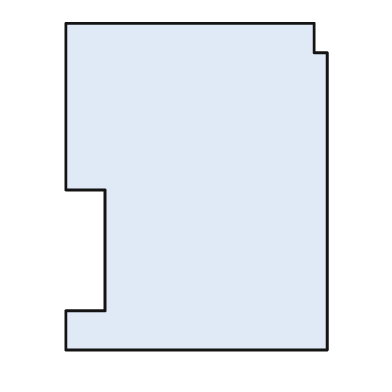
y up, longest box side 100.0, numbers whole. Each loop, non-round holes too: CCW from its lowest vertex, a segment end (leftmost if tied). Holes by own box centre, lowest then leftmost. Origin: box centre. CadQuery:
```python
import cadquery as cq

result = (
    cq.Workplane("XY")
    .moveTo(-40.0, -50.0)
    .lineTo(40.0, -50.0)
    .lineTo(40.0, 41.0)
    .lineTo(36.0, 41.0)
    .lineTo(36.0, 50.0)
    .lineTo(-40.0, 50.0)
    .lineTo(-40.0, -1.0)
    .lineTo(-28.0, -1.0)
    .lineTo(-28.0, -38.0)
    .lineTo(-40.0, -38.0)
    .close()
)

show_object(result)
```